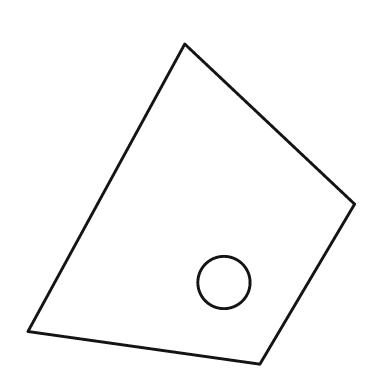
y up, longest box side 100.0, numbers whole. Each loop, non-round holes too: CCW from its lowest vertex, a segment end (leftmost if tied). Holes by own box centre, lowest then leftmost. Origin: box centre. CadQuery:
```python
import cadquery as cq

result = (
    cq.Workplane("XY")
    .moveTo(21.0, -49.0)
    .lineTo(50.0, 0.0)
    .lineTo(-2.0, 49.0)
    .lineTo(-50.0, -39.0)
    .close()
    .moveTo(10.0, -24.0)
    .circle(8.0)
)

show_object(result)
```